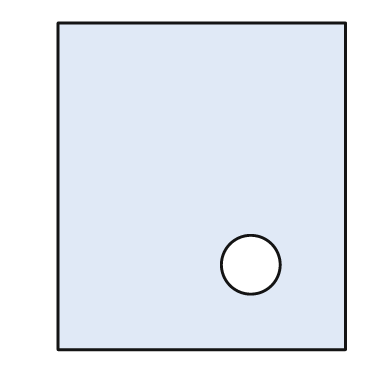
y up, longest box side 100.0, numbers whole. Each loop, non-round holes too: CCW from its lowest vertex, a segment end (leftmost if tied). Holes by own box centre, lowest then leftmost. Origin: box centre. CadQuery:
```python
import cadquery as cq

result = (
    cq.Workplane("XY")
    .moveTo(-44.0, -50.0)
    .lineTo(44.0, -50.0)
    .lineTo(44.0, 50.0)
    .lineTo(-44.0, 50.0)
    .close()
    .moveTo(15.0, -24.0)
    .circle(9.0)
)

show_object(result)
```